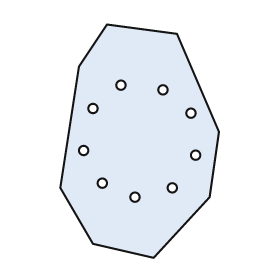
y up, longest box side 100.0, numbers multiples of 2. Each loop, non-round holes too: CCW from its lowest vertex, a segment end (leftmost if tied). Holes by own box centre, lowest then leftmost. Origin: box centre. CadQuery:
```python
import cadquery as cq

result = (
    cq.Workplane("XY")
    .moveTo(6.0, -50.0)
    .lineTo(30.0, -24.0)
    .lineTo(34.0, 4.0)
    .lineTo(16.0, 46.0)
    .lineTo(-14.0, 50.0)
    .lineTo(-26.0, 32.0)
    .lineTo(-34.0, -20.0)
    .lineTo(-20.0, -44.0)
    .close()
    .moveTo(-2.0, -24.0)
    .circle(2.0)
    .moveTo(14.0, -20.0)
    .circle(2.0)
    .moveTo(-16.0, -18.0)
    .circle(2.0)
    .moveTo(24.0, -6.0)
    .circle(2.0)
    .moveTo(-24.0, -4.0)
    .circle(2.0)
    .moveTo(22.0, 12.0)
    .circle(2.0)
    .moveTo(-20.0, 14.0)
    .circle(2.0)
    .moveTo(10.0, 22.0)
    .circle(2.0)
    .moveTo(-8.0, 24.0)
    .circle(2.0)
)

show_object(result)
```